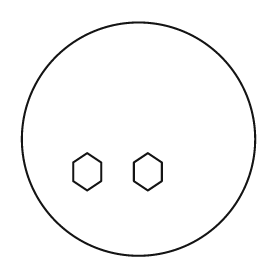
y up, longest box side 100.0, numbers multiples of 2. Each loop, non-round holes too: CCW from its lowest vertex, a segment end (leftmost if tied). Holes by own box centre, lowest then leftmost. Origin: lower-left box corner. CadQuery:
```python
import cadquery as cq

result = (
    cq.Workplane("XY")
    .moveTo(50.0, 50.0)
    .circle(50.0)
    .moveTo(28.0, 28.0)
    .lineTo(34.0, 32.0)
    .lineTo(34.0, 40.0)
    .lineTo(28.0, 44.0)
    .lineTo(22.0, 40.0)
    .lineTo(22.0, 32.0)
    .close()
    .moveTo(54.0, 28.0)
    .lineTo(60.0, 32.0)
    .lineTo(60.0, 40.0)
    .lineTo(54.0, 44.0)
    .lineTo(48.0, 40.0)
    .lineTo(48.0, 32.0)
    .close()
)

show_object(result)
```